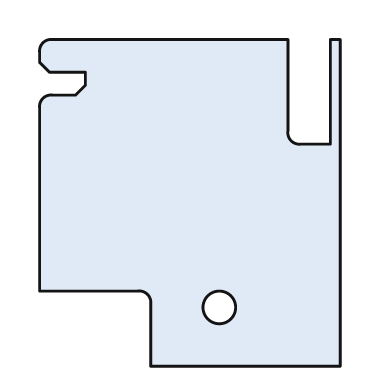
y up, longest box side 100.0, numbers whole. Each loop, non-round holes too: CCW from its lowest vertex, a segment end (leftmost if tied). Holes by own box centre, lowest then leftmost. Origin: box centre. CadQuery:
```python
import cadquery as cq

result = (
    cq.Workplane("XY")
    .moveTo(-12.0, -50.0)
    .lineTo(46.0, -50.0)
    .lineTo(46.0, 50.0)
    .lineTo(43.0, 50.0)
    .lineTo(43.0, 18.0)
    .lineTo(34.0, 18.0)
    .threePointArc((31.0, 19.0), (30.0, 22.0))
    .lineTo(30.0, 50.0)
    .lineTo(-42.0, 50.0)
    .threePointArc((-45.0, 49.0), (-46.0, 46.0))
    .lineTo(-46.0, 43.0)
    .lineTo(-43.0, 40.0)
    .lineTo(-32.0, 40.0)
    .lineTo(-32.0, 36.0)
    .lineTo(-35.0, 33.0)
    .lineTo(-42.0, 33.0)
    .threePointArc((-45.0, 32.0), (-46.0, 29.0))
    .lineTo(-46.0, -27.0)
    .lineTo(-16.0, -27.0)
    .threePointArc((-13.0, -28.0), (-12.0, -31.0))
    .close()
    .moveTo(9.0, -32.0)
    .circle(5.0)
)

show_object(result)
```